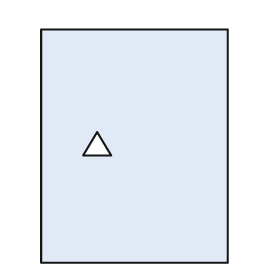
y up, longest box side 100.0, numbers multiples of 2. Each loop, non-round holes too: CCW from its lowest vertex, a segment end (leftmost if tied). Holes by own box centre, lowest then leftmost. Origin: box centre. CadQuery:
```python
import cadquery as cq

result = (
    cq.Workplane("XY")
    .moveTo(-40.0, -50.0)
    .lineTo(40.0, -50.0)
    .lineTo(40.0, 50.0)
    .lineTo(-40.0, 50.0)
    .close()
    .moveTo(-22.0, -4.0)
    .lineTo(-10.0, -4.0)
    .lineTo(-16.0, 6.0)
    .close()
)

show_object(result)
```